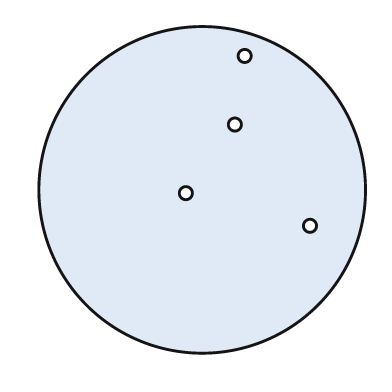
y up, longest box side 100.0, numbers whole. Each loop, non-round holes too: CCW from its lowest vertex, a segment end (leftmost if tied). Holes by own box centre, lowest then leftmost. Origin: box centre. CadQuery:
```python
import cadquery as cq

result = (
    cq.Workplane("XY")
    .moveTo(0.0, 0.0)
    .circle(50.0)
    .moveTo(33.0, -11.0)
    .circle(2.0)
    .moveTo(-5.0, -1.0)
    .circle(2.0)
    .moveTo(10.0, 20.0)
    .circle(2.0)
    .moveTo(13.0, 41.0)
    .circle(2.0)
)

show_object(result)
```